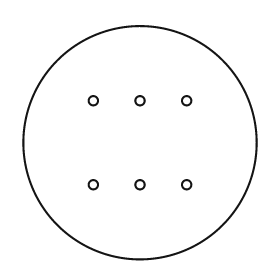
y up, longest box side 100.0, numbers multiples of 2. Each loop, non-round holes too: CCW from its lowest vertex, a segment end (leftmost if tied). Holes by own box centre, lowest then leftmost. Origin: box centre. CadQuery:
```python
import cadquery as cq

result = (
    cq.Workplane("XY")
    .moveTo(0.0, 0.0)
    .circle(50.0)
    .moveTo(-20.0, -18.0)
    .circle(2.0)
    .moveTo(0.0, -18.0)
    .circle(2.0)
    .moveTo(20.0, -18.0)
    .circle(2.0)
    .moveTo(-20.0, 18.0)
    .circle(2.0)
    .moveTo(0.0, 18.0)
    .circle(2.0)
    .moveTo(20.0, 18.0)
    .circle(2.0)
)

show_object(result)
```